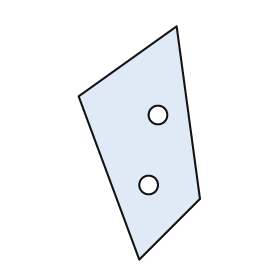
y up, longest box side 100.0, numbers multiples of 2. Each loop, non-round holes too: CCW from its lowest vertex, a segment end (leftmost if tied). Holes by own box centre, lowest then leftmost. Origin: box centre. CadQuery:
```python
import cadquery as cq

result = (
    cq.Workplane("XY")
    .moveTo(0.0, -50.0)
    .lineTo(26.0, -24.0)
    .lineTo(16.0, 50.0)
    .lineTo(-26.0, 20.0)
    .close()
    .moveTo(4.0, -18.0)
    .circle(4.0)
    .moveTo(8.0, 12.0)
    .circle(4.0)
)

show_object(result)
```